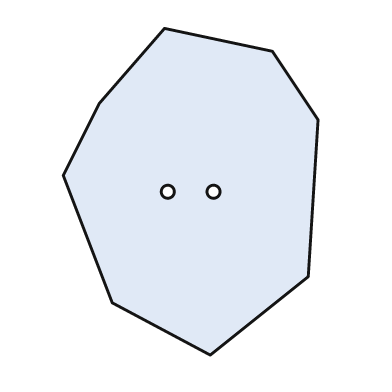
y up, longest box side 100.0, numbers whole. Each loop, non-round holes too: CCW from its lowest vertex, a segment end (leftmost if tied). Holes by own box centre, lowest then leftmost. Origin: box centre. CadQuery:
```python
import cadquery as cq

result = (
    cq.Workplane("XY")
    .moveTo(6.0, -50.0)
    .lineTo(36.0, -26.0)
    .lineTo(39.0, 22.0)
    .lineTo(25.0, 43.0)
    .lineTo(-8.0, 50.0)
    .lineTo(-28.0, 27.0)
    .lineTo(-39.0, 5.0)
    .lineTo(-24.0, -34.0)
    .close()
    .moveTo(-7.0, 0.0)
    .circle(2.0)
    .moveTo(7.0, 0.0)
    .circle(2.0)
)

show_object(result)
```